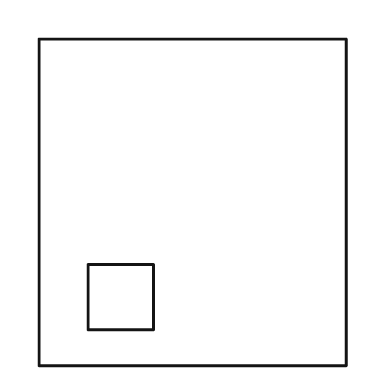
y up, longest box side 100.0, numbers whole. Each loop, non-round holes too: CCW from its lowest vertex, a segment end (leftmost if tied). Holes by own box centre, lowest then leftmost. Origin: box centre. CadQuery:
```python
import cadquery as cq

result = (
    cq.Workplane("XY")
    .moveTo(-47.0, -50.0)
    .lineTo(47.0, -50.0)
    .lineTo(47.0, 50.0)
    .lineTo(-47.0, 50.0)
    .close()
    .moveTo(-32.0, -39.0)
    .lineTo(-12.0, -39.0)
    .lineTo(-12.0, -19.0)
    .lineTo(-32.0, -19.0)
    .close()
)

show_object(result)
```